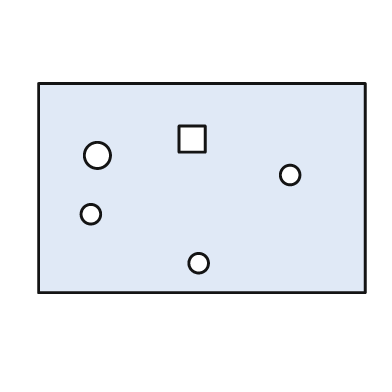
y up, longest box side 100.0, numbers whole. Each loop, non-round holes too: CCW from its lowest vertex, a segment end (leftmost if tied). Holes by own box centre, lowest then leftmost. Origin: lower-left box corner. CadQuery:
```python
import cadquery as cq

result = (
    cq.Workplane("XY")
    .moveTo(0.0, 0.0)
    .lineTo(100.0, 0.0)
    .lineTo(100.0, 64.0)
    .lineTo(0.0, 64.0)
    .close()
    .moveTo(49.0, 9.0)
    .circle(3.0)
    .moveTo(16.0, 24.0)
    .circle(3.0)
    .moveTo(77.0, 36.0)
    .circle(3.0)
    .moveTo(18.0, 42.0)
    .circle(4.0)
    .moveTo(43.0, 43.0)
    .lineTo(51.0, 43.0)
    .lineTo(51.0, 51.0)
    .lineTo(43.0, 51.0)
    .close()
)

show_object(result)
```